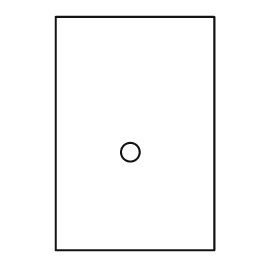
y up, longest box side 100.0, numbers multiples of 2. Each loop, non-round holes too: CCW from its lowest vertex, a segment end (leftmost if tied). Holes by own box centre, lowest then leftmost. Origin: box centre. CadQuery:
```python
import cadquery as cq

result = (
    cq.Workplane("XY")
    .moveTo(-34.0, -50.0)
    .lineTo(34.0, -50.0)
    .lineTo(34.0, 50.0)
    .lineTo(-34.0, 50.0)
    .close()
    .moveTo(-2.0, -8.0)
    .circle(4.0)
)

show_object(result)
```